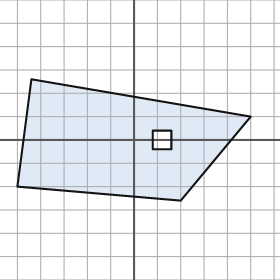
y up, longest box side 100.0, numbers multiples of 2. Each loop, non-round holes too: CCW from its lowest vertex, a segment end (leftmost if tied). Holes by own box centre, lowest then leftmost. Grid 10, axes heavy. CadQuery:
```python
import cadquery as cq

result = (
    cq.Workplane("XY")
    .moveTo(20.0, -26.0)
    .lineTo(50.0, 10.0)
    .lineTo(-44.0, 26.0)
    .lineTo(-50.0, -20.0)
    .close()
    .moveTo(8.0, -4.0)
    .lineTo(16.0, -4.0)
    .lineTo(16.0, 4.0)
    .lineTo(8.0, 4.0)
    .close()
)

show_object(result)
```